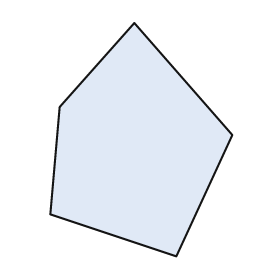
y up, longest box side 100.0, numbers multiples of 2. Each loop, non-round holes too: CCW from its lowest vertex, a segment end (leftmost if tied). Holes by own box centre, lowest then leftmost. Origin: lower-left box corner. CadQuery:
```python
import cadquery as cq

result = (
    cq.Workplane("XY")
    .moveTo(54.0, 0.0)
    .lineTo(78.0, 52.0)
    .lineTo(36.0, 100.0)
    .lineTo(4.0, 64.0)
    .lineTo(0.0, 18.0)
    .close()
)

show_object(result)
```